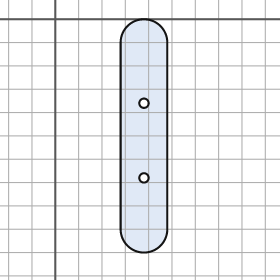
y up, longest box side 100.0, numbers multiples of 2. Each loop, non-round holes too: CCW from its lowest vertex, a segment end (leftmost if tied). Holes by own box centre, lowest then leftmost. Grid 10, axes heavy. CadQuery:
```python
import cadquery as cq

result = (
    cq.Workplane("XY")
    .moveTo(28.0, -90.0)
    .threePointArc((38.0, -100.0), (48.0, -90.0))
    .lineTo(48.0, -10.0)
    .threePointArc((38.0, 0.0), (28.0, -10.0))
    .close()
    .moveTo(38.0, -68.0)
    .circle(2.0)
    .moveTo(38.0, -36.0)
    .circle(2.0)
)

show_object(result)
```